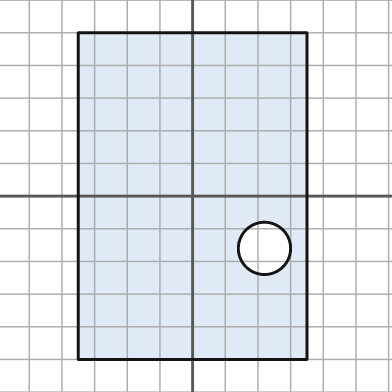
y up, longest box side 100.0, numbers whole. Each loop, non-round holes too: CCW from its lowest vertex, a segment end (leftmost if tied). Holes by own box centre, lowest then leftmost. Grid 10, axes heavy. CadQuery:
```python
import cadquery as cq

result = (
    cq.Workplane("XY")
    .moveTo(-35.0, -50.0)
    .lineTo(35.0, -50.0)
    .lineTo(35.0, 50.0)
    .lineTo(-35.0, 50.0)
    .close()
    .moveTo(22.0, -16.0)
    .circle(8.0)
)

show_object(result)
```